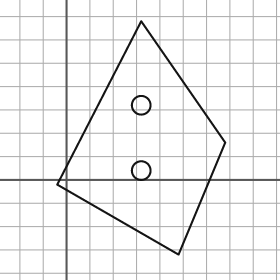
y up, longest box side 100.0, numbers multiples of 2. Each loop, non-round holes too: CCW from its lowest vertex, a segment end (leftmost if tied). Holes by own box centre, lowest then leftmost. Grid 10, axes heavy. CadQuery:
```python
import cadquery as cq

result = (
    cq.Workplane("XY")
    .moveTo(48.0, -32.0)
    .lineTo(68.0, 16.0)
    .lineTo(32.0, 68.0)
    .lineTo(-4.0, -2.0)
    .close()
    .moveTo(32.0, 4.0)
    .circle(4.0)
    .moveTo(32.0, 32.0)
    .circle(4.0)
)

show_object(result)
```